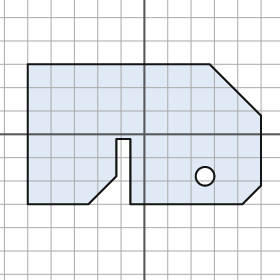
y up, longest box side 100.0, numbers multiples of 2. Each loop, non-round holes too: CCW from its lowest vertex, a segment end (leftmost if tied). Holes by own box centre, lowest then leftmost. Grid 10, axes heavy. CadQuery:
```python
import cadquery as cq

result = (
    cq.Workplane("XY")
    .moveTo(-50.0, -30.0)
    .lineTo(-24.0, -30.0)
    .lineTo(-12.0, -18.0)
    .lineTo(-12.0, -2.0)
    .lineTo(-6.0, -2.0)
    .lineTo(-6.0, -30.0)
    .lineTo(42.0, -30.0)
    .lineTo(50.0, -22.0)
    .lineTo(50.0, 8.0)
    .lineTo(28.0, 30.0)
    .lineTo(-50.0, 30.0)
    .close()
    .moveTo(26.0, -18.0)
    .circle(4.0)
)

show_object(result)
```